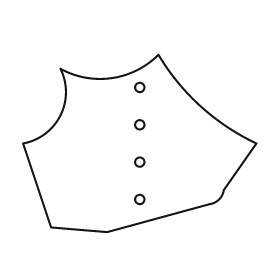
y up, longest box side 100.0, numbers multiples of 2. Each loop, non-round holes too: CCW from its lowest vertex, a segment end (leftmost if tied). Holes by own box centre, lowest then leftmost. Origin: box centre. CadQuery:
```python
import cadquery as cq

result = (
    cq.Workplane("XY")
    .moveTo(-14.0, -38.0)
    .lineTo(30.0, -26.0)
    .threePointArc((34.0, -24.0), (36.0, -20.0))
    .lineTo(50.0, 0.0)
    .threePointArc((26.0, 16.0), (8.0, 38.0))
    .threePointArc((-12.0, 28.0), (-34.0, 32.0))
    .threePointArc((-34.0, 12.0), (-50.0, 0.0))
    .lineTo(-38.0, -36.0)
    .close()
    .moveTo(0.0, -24.0)
    .circle(2.0)
    .moveTo(0.0, -8.0)
    .circle(2.0)
    .moveTo(0.0, 8.0)
    .circle(2.0)
    .moveTo(0.0, 24.0)
    .circle(2.0)
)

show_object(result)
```